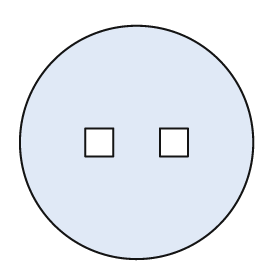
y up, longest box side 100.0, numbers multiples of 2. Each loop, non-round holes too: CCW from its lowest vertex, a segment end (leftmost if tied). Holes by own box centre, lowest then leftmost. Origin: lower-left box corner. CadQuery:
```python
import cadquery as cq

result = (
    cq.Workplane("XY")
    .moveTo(50.0, 50.0)
    .circle(50.0)
    .moveTo(28.0, 44.0)
    .lineTo(40.0, 44.0)
    .lineTo(40.0, 56.0)
    .lineTo(28.0, 56.0)
    .close()
    .moveTo(60.0, 44.0)
    .lineTo(72.0, 44.0)
    .lineTo(72.0, 56.0)
    .lineTo(60.0, 56.0)
    .close()
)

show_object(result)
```